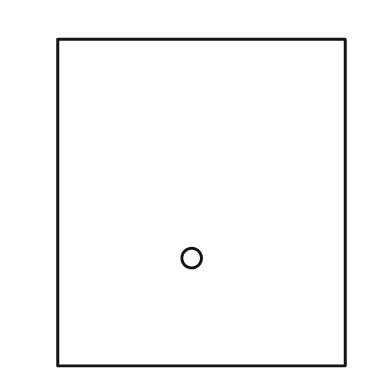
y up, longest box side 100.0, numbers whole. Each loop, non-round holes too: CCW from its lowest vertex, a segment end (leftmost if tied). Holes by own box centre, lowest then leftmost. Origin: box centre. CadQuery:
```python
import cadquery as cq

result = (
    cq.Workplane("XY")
    .moveTo(-44.0, -50.0)
    .lineTo(44.0, -50.0)
    .lineTo(44.0, 50.0)
    .lineTo(-44.0, 50.0)
    .close()
    .moveTo(-3.0, -17.0)
    .circle(3.0)
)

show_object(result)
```